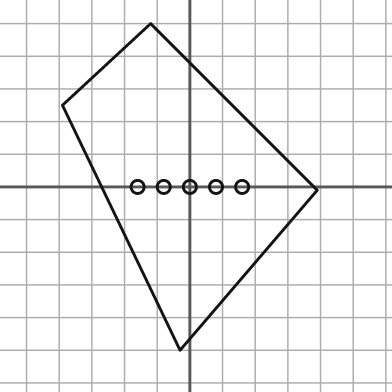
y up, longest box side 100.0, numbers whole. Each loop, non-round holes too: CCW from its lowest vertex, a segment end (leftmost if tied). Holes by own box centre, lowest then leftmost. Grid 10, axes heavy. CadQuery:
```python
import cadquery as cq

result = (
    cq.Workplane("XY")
    .moveTo(-3.0, -50.0)
    .lineTo(39.0, -1.0)
    .lineTo(-12.0, 50.0)
    .lineTo(-39.0, 25.0)
    .close()
    .moveTo(-16.0, 0.0)
    .circle(2.0)
    .moveTo(-8.0, 0.0)
    .circle(2.0)
    .moveTo(0.0, 0.0)
    .circle(2.0)
    .moveTo(8.0, 0.0)
    .circle(2.0)
    .moveTo(16.0, 0.0)
    .circle(2.0)
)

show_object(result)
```